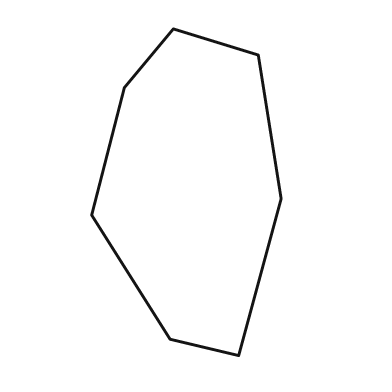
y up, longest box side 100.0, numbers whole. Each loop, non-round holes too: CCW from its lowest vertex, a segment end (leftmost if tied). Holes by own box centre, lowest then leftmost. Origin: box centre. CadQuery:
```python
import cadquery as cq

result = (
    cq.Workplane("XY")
    .moveTo(16.0, -50.0)
    .lineTo(29.0, -2.0)
    .lineTo(22.0, 42.0)
    .lineTo(-4.0, 50.0)
    .lineTo(-19.0, 32.0)
    .lineTo(-29.0, -7.0)
    .lineTo(-5.0, -45.0)
    .close()
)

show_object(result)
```